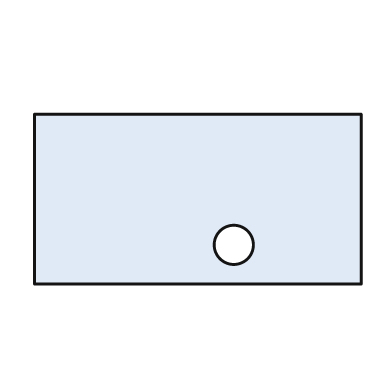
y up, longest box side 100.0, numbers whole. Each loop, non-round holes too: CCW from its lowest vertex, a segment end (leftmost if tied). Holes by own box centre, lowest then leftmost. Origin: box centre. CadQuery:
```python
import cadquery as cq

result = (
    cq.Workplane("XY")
    .moveTo(-50.0, -26.0)
    .lineTo(50.0, -26.0)
    .lineTo(50.0, 26.0)
    .lineTo(-50.0, 26.0)
    .close()
    .moveTo(11.0, -14.0)
    .circle(6.0)
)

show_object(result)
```